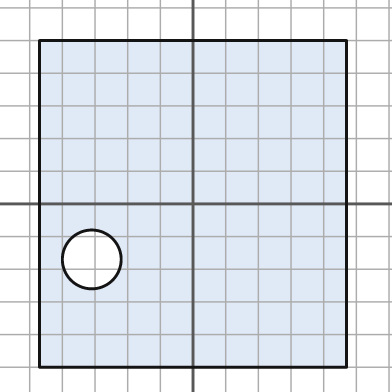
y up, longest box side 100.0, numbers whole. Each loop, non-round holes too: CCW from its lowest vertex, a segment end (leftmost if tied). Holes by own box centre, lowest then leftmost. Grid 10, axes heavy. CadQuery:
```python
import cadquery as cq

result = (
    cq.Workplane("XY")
    .moveTo(-47.0, -50.0)
    .lineTo(47.0, -50.0)
    .lineTo(47.0, 50.0)
    .lineTo(-47.0, 50.0)
    .close()
    .moveTo(-31.0, -17.0)
    .circle(9.0)
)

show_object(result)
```